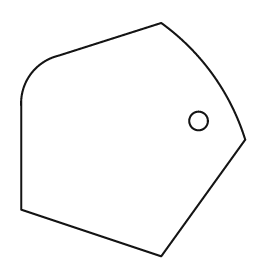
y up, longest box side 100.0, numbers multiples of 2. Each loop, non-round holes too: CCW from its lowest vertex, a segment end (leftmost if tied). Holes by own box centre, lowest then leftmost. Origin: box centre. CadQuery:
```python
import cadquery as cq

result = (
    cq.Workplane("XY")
    .moveTo(12.0, -50.0)
    .lineTo(48.0, 0.0)
    .threePointArc((34.0, 28.0), (12.0, 50.0))
    .lineTo(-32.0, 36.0)
    .threePointArc((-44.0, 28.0), (-48.0, 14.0))
    .lineTo(-48.0, -30.0)
    .close()
    .moveTo(28.0, 8.0)
    .circle(4.0)
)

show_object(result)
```